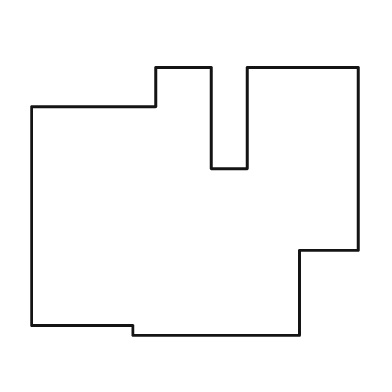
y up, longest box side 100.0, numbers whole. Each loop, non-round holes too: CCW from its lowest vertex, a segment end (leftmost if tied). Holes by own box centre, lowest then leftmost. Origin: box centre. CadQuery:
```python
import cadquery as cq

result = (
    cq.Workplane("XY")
    .moveTo(-19.0, -41.0)
    .lineTo(32.0, -41.0)
    .lineTo(32.0, -15.0)
    .lineTo(50.0, -15.0)
    .lineTo(50.0, 41.0)
    .lineTo(16.0, 41.0)
    .lineTo(16.0, 10.0)
    .lineTo(5.0, 10.0)
    .lineTo(5.0, 41.0)
    .lineTo(-12.0, 41.0)
    .lineTo(-12.0, 29.0)
    .lineTo(-50.0, 29.0)
    .lineTo(-50.0, -38.0)
    .lineTo(-19.0, -38.0)
    .close()
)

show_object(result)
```